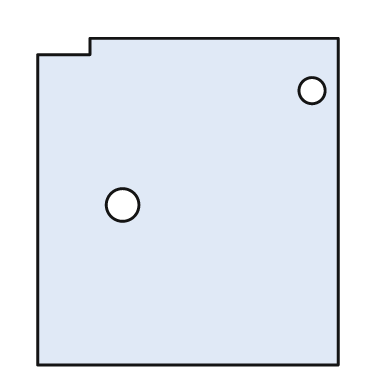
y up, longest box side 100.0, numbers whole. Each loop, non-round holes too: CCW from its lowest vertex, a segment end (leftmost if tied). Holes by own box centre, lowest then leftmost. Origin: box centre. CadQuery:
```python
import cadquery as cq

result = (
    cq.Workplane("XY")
    .moveTo(-46.0, -50.0)
    .lineTo(46.0, -50.0)
    .lineTo(46.0, 50.0)
    .lineTo(-30.0, 50.0)
    .lineTo(-30.0, 45.0)
    .lineTo(-46.0, 45.0)
    .close()
    .moveTo(-20.0, -1.0)
    .circle(5.0)
    .moveTo(38.0, 34.0)
    .circle(4.0)
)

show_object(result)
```